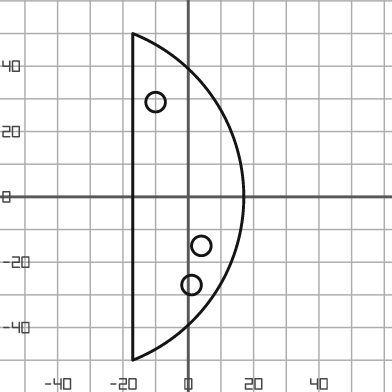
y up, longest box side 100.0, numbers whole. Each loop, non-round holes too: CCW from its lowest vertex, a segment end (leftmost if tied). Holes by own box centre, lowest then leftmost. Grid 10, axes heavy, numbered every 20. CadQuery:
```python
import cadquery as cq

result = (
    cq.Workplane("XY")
    .moveTo(-17.0, -50.0)
    .threePointArc((17.0, 0.0), (-17.0, 50.0))
    .close()
    .moveTo(1.0, -27.0)
    .circle(3.0)
    .moveTo(4.0, -15.0)
    .circle(3.0)
    .moveTo(-10.0, 29.0)
    .circle(3.0)
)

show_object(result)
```